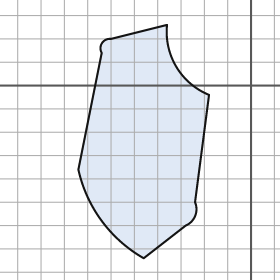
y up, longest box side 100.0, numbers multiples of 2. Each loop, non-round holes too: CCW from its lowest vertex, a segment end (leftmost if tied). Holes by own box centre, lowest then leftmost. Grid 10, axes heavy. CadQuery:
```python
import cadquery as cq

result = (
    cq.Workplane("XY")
    .moveTo(-46.0, -74.0)
    .lineTo(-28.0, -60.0)
    .threePointArc((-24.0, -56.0), (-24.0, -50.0))
    .lineTo(-18.0, -4.0)
    .threePointArc((-32.0, 8.0), (-36.0, 26.0))
    .lineTo(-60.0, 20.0)
    .threePointArc((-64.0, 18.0), (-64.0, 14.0))
    .lineTo(-74.0, -36.0)
    .threePointArc((-64.0, -58.0), (-46.0, -74.0))
    .close()
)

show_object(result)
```